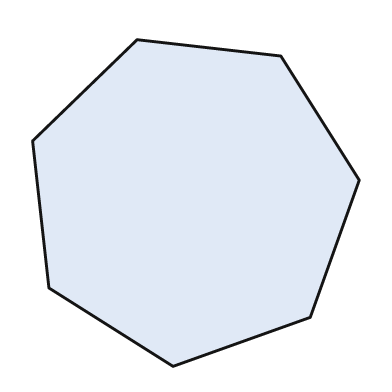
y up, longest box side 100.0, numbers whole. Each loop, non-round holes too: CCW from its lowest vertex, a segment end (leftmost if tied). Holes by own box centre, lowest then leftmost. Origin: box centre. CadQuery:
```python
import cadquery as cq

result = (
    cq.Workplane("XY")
    .moveTo(-7.0, -50.0)
    .lineTo(35.0, -35.0)
    .lineTo(50.0, 7.0)
    .lineTo(26.0, 45.0)
    .lineTo(-18.0, 50.0)
    .lineTo(-50.0, 19.0)
    .lineTo(-45.0, -26.0)
    .close()
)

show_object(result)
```